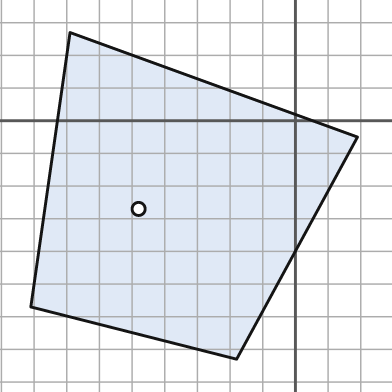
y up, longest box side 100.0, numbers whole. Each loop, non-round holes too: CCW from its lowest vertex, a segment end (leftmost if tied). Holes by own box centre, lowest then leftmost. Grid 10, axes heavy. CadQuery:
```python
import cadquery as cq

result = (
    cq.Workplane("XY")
    .moveTo(-18.0, -73.0)
    .lineTo(19.0, -5.0)
    .lineTo(-69.0, 27.0)
    .lineTo(-81.0, -57.0)
    .close()
    .moveTo(-48.0, -27.0)
    .circle(2.0)
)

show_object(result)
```